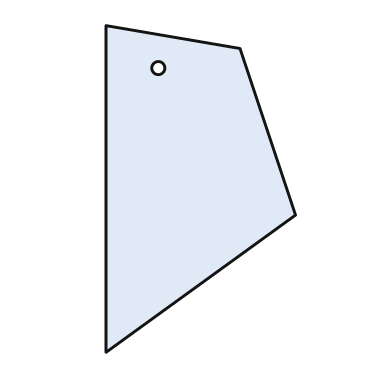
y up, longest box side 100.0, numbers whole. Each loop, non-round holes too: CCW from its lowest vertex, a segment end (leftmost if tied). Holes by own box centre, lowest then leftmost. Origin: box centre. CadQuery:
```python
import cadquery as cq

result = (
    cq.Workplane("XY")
    .moveTo(-29.0, -50.0)
    .lineTo(29.0, -8.0)
    .lineTo(12.0, 43.0)
    .lineTo(-29.0, 50.0)
    .close()
    .moveTo(-13.0, 37.0)
    .circle(2.0)
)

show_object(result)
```